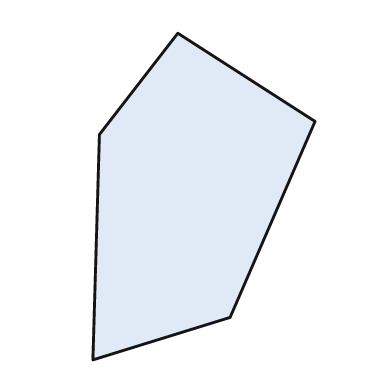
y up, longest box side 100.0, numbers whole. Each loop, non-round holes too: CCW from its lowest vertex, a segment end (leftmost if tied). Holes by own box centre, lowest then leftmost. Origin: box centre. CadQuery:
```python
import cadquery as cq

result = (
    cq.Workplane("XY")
    .moveTo(-34.0, -50.0)
    .lineTo(8.0, -37.0)
    .lineTo(34.0, 23.0)
    .lineTo(-8.0, 50.0)
    .lineTo(-32.0, 19.0)
    .close()
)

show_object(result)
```